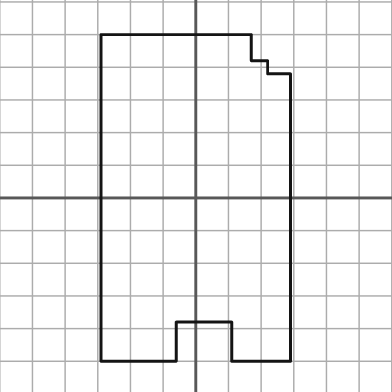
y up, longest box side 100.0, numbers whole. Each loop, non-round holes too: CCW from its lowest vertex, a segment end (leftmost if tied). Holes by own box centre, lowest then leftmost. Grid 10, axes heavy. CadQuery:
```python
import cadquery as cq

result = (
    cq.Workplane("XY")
    .moveTo(-29.0, -50.0)
    .lineTo(-6.0, -50.0)
    .lineTo(-6.0, -38.0)
    .lineTo(11.0, -38.0)
    .lineTo(11.0, -50.0)
    .lineTo(29.0, -50.0)
    .lineTo(29.0, 38.0)
    .lineTo(22.0, 38.0)
    .lineTo(22.0, 42.0)
    .lineTo(17.0, 42.0)
    .lineTo(17.0, 50.0)
    .lineTo(-29.0, 50.0)
    .close()
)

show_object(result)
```